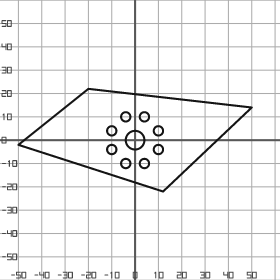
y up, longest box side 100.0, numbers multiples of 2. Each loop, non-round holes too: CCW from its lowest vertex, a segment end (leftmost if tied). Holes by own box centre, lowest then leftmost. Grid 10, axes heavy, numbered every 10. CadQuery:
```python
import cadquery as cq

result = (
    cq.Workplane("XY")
    .moveTo(12.0, -22.0)
    .lineTo(50.0, 14.0)
    .lineTo(-20.0, 22.0)
    .lineTo(-50.0, -2.0)
    .close()
    .moveTo(-4.0, -10.0)
    .circle(2.0)
    .moveTo(4.0, -10.0)
    .circle(2.0)
    .moveTo(-10.0, -4.0)
    .circle(2.0)
    .moveTo(10.0, -4.0)
    .circle(2.0)
    .moveTo(0.0, 0.0)
    .circle(4.0)
    .moveTo(-10.0, 4.0)
    .circle(2.0)
    .moveTo(10.0, 4.0)
    .circle(2.0)
    .moveTo(-4.0, 10.0)
    .circle(2.0)
    .moveTo(4.0, 10.0)
    .circle(2.0)
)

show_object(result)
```